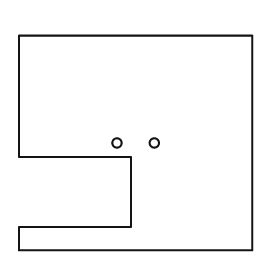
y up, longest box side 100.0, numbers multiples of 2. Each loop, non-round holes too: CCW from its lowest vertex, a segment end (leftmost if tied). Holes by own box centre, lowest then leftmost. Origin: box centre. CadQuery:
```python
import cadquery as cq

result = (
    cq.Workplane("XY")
    .moveTo(-50.0, -46.0)
    .lineTo(50.0, -46.0)
    .lineTo(50.0, 46.0)
    .lineTo(-50.0, 46.0)
    .lineTo(-50.0, -6.0)
    .lineTo(-2.0, -6.0)
    .lineTo(-2.0, -36.0)
    .lineTo(-50.0, -36.0)
    .close()
    .moveTo(-8.0, 0.0)
    .circle(2.0)
    .moveTo(8.0, 0.0)
    .circle(2.0)
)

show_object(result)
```